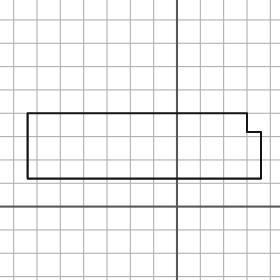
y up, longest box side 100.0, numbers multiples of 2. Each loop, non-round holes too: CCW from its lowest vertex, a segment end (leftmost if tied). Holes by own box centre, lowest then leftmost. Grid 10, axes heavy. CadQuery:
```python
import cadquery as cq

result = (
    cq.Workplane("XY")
    .moveTo(-64.0, 12.0)
    .lineTo(36.0, 12.0)
    .lineTo(36.0, 32.0)
    .lineTo(30.0, 32.0)
    .lineTo(30.0, 40.0)
    .lineTo(-64.0, 40.0)
    .close()
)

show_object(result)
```